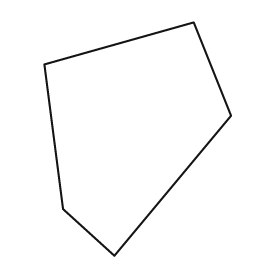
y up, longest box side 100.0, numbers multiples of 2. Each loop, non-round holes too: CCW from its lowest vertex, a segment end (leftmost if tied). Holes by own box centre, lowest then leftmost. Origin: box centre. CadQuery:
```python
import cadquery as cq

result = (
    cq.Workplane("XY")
    .moveTo(-10.0, -50.0)
    .lineTo(40.0, 10.0)
    .lineTo(24.0, 50.0)
    .lineTo(-40.0, 32.0)
    .lineTo(-32.0, -30.0)
    .close()
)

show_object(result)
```